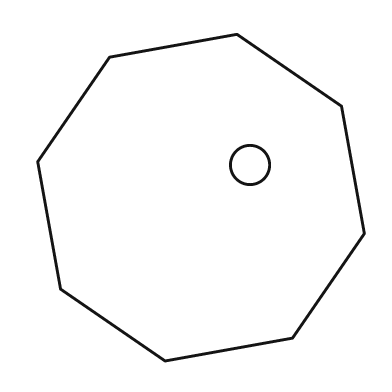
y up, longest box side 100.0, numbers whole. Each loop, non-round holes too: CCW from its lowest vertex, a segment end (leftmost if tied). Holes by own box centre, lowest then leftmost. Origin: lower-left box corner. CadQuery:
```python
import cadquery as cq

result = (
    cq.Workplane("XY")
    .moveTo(39.0, 0.0)
    .lineTo(78.0, 7.0)
    .lineTo(100.0, 39.0)
    .lineTo(93.0, 78.0)
    .lineTo(61.0, 100.0)
    .lineTo(22.0, 93.0)
    .lineTo(0.0, 61.0)
    .lineTo(7.0, 22.0)
    .close()
    .moveTo(65.0, 60.0)
    .circle(6.0)
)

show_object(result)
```